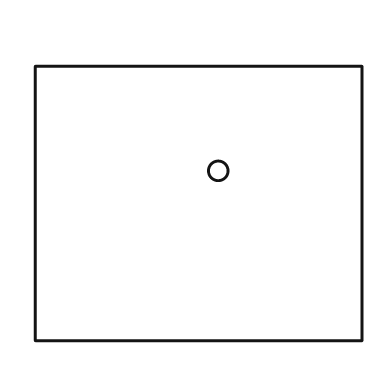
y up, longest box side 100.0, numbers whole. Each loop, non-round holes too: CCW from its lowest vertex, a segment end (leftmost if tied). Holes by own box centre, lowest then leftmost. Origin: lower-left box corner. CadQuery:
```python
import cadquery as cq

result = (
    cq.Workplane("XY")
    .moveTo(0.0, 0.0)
    .lineTo(100.0, 0.0)
    .lineTo(100.0, 84.0)
    .lineTo(0.0, 84.0)
    .close()
    .moveTo(56.0, 52.0)
    .circle(3.0)
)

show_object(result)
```